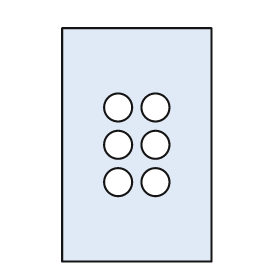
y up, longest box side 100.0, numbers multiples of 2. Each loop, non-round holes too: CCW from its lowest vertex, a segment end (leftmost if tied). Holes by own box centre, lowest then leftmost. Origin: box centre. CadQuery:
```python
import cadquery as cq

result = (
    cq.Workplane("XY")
    .moveTo(-32.0, -50.0)
    .lineTo(32.0, -50.0)
    .lineTo(32.0, 50.0)
    .lineTo(-32.0, 50.0)
    .close()
    .moveTo(-8.0, -16.0)
    .circle(6.0)
    .moveTo(8.0, -16.0)
    .circle(6.0)
    .moveTo(-8.0, 0.0)
    .circle(6.0)
    .moveTo(8.0, 0.0)
    .circle(6.0)
    .moveTo(-8.0, 16.0)
    .circle(6.0)
    .moveTo(8.0, 16.0)
    .circle(6.0)
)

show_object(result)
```